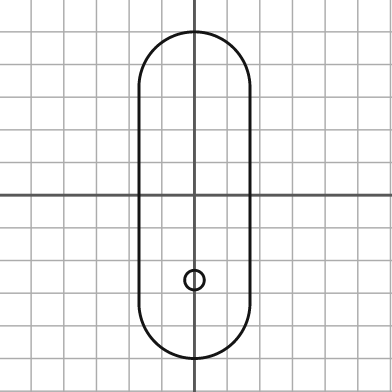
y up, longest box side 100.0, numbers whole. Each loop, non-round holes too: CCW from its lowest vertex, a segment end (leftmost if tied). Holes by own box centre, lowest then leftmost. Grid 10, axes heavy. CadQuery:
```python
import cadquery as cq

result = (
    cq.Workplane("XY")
    .moveTo(-17.0, -33.0)
    .threePointArc((0.0, -50.0), (17.0, -33.0))
    .lineTo(17.0, 33.0)
    .threePointArc((0.0, 50.0), (-17.0, 33.0))
    .close()
    .moveTo(0.0, -26.0)
    .circle(3.0)
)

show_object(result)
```